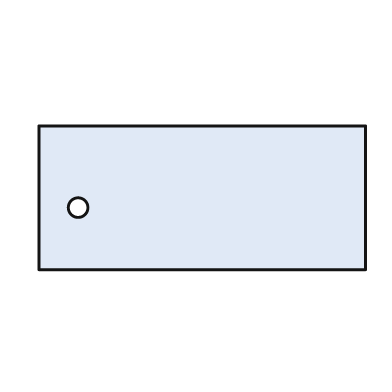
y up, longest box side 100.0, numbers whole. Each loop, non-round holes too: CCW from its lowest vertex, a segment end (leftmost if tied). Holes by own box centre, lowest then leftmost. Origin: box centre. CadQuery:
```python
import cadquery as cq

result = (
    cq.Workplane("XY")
    .moveTo(-50.0, -22.0)
    .lineTo(50.0, -22.0)
    .lineTo(50.0, 22.0)
    .lineTo(-50.0, 22.0)
    .close()
    .moveTo(-38.0, -3.0)
    .circle(3.0)
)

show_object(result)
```